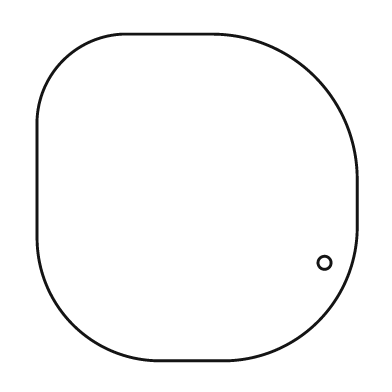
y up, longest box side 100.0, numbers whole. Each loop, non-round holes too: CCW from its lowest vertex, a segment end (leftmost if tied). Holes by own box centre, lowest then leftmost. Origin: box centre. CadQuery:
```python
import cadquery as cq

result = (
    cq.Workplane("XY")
    .moveTo(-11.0, -50.0)
    .lineTo(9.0, -50.0)
    .threePointArc((37.0, -38.0), (49.0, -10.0))
    .lineTo(49.0, 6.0)
    .threePointArc((36.0, 37.0), (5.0, 50.0))
    .lineTo(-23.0, 50.0)
    .threePointArc((-41.0, 42.0), (-49.0, 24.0))
    .lineTo(-49.0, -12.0)
    .threePointArc((-38.0, -39.0), (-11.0, -50.0))
    .close()
    .moveTo(39.0, -20.0)
    .circle(2.0)
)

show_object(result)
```